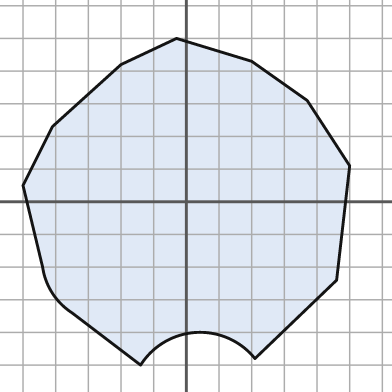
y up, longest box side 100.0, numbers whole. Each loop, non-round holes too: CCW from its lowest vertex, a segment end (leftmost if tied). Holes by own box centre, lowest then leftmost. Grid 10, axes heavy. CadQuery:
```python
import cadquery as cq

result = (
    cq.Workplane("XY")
    .moveTo(-14.0, -50.0)
    .threePointArc((3.0, -40.0), (21.0, -48.0))
    .lineTo(46.0, -24.0)
    .lineTo(50.0, 11.0)
    .lineTo(37.0, 31.0)
    .lineTo(20.0, 43.0)
    .lineTo(-3.0, 50.0)
    .lineTo(-20.0, 42.0)
    .lineTo(-41.0, 23.0)
    .lineTo(-50.0, 5.0)
    .lineTo(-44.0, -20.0)
    .threePointArc((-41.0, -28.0), (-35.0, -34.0))
    .close()
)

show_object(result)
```